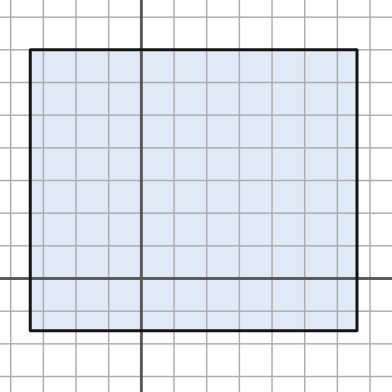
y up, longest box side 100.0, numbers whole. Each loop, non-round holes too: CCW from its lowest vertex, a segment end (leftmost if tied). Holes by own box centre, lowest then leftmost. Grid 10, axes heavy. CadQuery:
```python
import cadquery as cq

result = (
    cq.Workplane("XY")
    .moveTo(-34.0, -16.0)
    .lineTo(66.0, -16.0)
    .lineTo(66.0, 70.0)
    .lineTo(-34.0, 70.0)
    .close()
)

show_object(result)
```